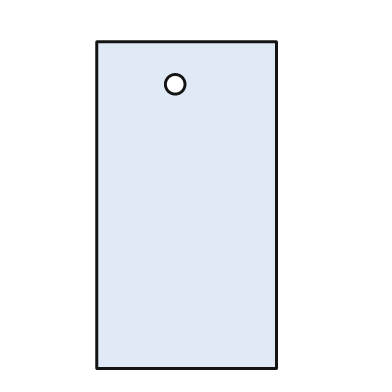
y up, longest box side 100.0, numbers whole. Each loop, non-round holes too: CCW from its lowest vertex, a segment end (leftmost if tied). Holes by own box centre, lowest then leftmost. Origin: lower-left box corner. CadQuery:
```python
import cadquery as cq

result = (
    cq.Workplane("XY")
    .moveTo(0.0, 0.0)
    .lineTo(55.0, 0.0)
    .lineTo(55.0, 100.0)
    .lineTo(0.0, 100.0)
    .close()
    .moveTo(24.0, 87.0)
    .circle(3.0)
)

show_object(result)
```